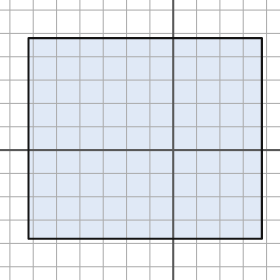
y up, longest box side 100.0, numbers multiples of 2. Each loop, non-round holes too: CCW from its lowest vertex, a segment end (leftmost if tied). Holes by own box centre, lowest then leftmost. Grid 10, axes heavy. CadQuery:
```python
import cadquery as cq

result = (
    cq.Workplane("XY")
    .moveTo(-62.0, -38.0)
    .lineTo(38.0, -38.0)
    .lineTo(38.0, 48.0)
    .lineTo(-62.0, 48.0)
    .close()
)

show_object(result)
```